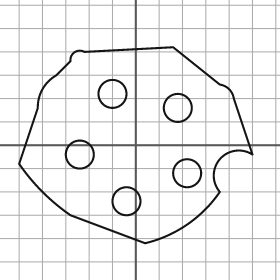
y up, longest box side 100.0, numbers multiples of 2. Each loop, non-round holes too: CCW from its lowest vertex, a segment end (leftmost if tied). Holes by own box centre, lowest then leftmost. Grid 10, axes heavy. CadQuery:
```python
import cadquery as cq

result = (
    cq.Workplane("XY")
    .moveTo(4.0, -42.0)
    .threePointArc((22.0, -34.0), (36.0, -20.0))
    .threePointArc((36.0, -6.0), (50.0, -4.0))
    .lineTo(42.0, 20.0)
    .threePointArc((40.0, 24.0), (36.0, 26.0))
    .lineTo(16.0, 42.0)
    .lineTo(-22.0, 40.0)
    .threePointArc((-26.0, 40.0), (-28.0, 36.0))
    .lineTo(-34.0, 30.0)
    .threePointArc((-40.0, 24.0), (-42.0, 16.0))
    .lineTo(-50.0, -8.0)
    .threePointArc((-40.0, -20.0), (-28.0, -30.0))
    .close()
    .moveTo(-4.0, -24.0)
    .circle(6.0)
    .moveTo(22.0, -12.0)
    .circle(6.0)
    .moveTo(-24.0, -4.0)
    .circle(6.0)
    .moveTo(18.0, 16.0)
    .circle(6.0)
    .moveTo(-10.0, 22.0)
    .circle(6.0)
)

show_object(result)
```